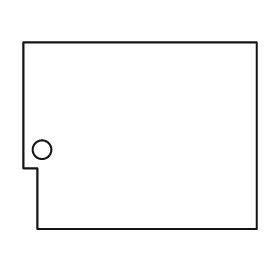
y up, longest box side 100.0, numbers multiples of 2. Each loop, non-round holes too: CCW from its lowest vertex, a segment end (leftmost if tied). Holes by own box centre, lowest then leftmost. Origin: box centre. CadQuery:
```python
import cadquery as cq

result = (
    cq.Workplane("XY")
    .moveTo(-44.0, -40.0)
    .lineTo(50.0, -40.0)
    .lineTo(50.0, 40.0)
    .lineTo(-50.0, 40.0)
    .lineTo(-50.0, -14.0)
    .lineTo(-44.0, -14.0)
    .close()
    .moveTo(-42.0, -6.0)
    .circle(4.0)
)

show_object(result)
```